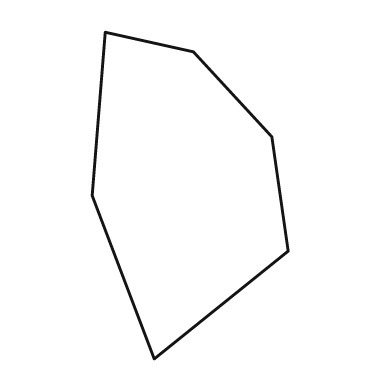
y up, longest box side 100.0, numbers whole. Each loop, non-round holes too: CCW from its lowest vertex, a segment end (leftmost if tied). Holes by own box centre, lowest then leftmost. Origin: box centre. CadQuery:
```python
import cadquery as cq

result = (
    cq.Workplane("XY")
    .moveTo(-11.0, -50.0)
    .lineTo(30.0, -17.0)
    .lineTo(25.0, 18.0)
    .lineTo(1.0, 44.0)
    .lineTo(-26.0, 50.0)
    .lineTo(-30.0, 0.0)
    .close()
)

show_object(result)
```